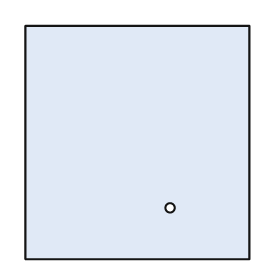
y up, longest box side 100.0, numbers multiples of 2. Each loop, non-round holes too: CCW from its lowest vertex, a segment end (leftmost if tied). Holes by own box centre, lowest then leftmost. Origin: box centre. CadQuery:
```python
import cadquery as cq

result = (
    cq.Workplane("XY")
    .moveTo(-48.0, -50.0)
    .lineTo(48.0, -50.0)
    .lineTo(48.0, 50.0)
    .lineTo(-48.0, 50.0)
    .close()
    .moveTo(14.0, -28.0)
    .circle(2.0)
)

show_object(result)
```